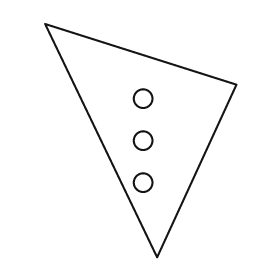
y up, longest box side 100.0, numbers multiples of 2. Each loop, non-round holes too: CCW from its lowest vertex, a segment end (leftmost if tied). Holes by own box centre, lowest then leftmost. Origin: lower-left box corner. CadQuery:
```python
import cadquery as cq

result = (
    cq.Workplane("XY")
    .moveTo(48.0, 0.0)
    .lineTo(82.0, 74.0)
    .lineTo(0.0, 100.0)
    .close()
    .moveTo(42.0, 32.0)
    .circle(4.0)
    .moveTo(42.0, 50.0)
    .circle(4.0)
    .moveTo(42.0, 68.0)
    .circle(4.0)
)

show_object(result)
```